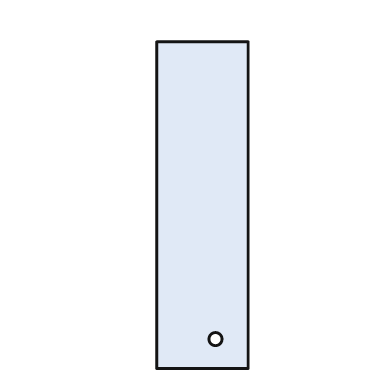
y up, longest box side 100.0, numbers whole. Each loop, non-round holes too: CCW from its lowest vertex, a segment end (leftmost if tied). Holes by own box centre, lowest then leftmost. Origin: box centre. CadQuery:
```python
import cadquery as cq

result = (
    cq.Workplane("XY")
    .moveTo(-14.0, -50.0)
    .lineTo(14.0, -50.0)
    .lineTo(14.0, 50.0)
    .lineTo(-14.0, 50.0)
    .close()
    .moveTo(4.0, -41.0)
    .circle(2.0)
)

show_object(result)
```